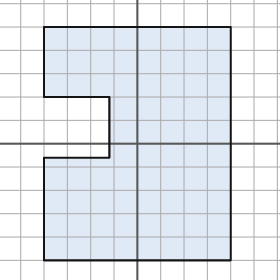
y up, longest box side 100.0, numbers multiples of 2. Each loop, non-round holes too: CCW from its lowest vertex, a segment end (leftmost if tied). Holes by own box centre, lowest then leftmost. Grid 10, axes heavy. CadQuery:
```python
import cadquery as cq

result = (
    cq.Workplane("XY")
    .moveTo(-40.0, -50.0)
    .lineTo(40.0, -50.0)
    .lineTo(40.0, 50.0)
    .lineTo(-40.0, 50.0)
    .lineTo(-40.0, 20.0)
    .lineTo(-12.0, 20.0)
    .lineTo(-12.0, -6.0)
    .lineTo(-40.0, -6.0)
    .close()
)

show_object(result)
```